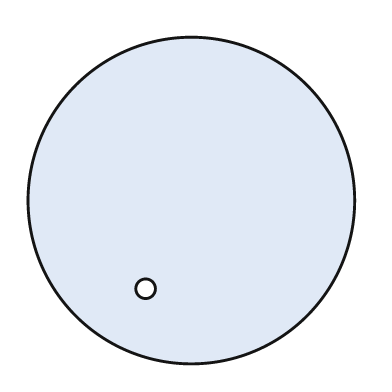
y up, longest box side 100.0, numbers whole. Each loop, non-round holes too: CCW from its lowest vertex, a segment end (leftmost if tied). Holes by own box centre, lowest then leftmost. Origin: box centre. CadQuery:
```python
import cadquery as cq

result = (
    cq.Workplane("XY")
    .moveTo(0.0, 0.0)
    .circle(50.0)
    .moveTo(-14.0, -27.0)
    .circle(3.0)
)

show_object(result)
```